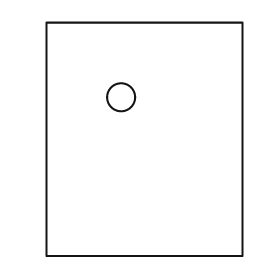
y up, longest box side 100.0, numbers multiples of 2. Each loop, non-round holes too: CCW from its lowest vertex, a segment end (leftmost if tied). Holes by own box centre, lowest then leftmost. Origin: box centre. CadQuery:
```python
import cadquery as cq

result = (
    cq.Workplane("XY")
    .moveTo(-42.0, -50.0)
    .lineTo(42.0, -50.0)
    .lineTo(42.0, 50.0)
    .lineTo(-42.0, 50.0)
    .close()
    .moveTo(-10.0, 18.0)
    .circle(6.0)
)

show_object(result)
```